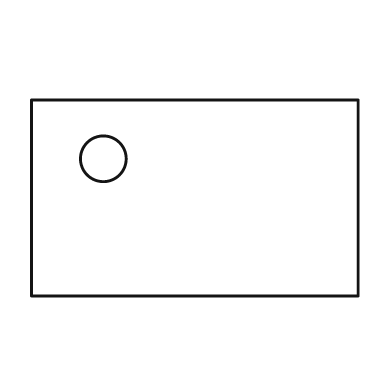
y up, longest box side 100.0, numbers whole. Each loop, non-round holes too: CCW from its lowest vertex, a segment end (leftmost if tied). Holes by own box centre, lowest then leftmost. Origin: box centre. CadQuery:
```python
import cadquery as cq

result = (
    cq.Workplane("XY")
    .moveTo(-50.0, -30.0)
    .lineTo(50.0, -30.0)
    .lineTo(50.0, 30.0)
    .lineTo(-50.0, 30.0)
    .close()
    .moveTo(-28.0, 12.0)
    .circle(7.0)
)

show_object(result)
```